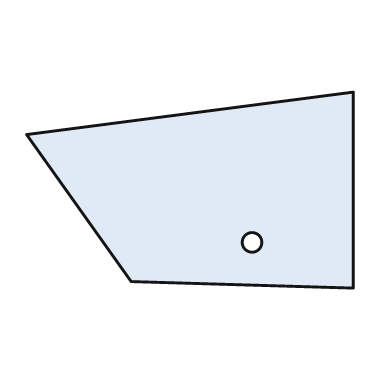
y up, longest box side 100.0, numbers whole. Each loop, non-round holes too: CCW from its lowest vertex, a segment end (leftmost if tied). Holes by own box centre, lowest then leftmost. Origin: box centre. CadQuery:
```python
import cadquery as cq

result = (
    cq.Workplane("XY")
    .moveTo(50.0, -30.0)
    .lineTo(50.0, 30.0)
    .lineTo(-50.0, 17.0)
    .lineTo(-18.0, -28.0)
    .close()
    .moveTo(19.0, -16.0)
    .circle(3.0)
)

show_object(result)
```